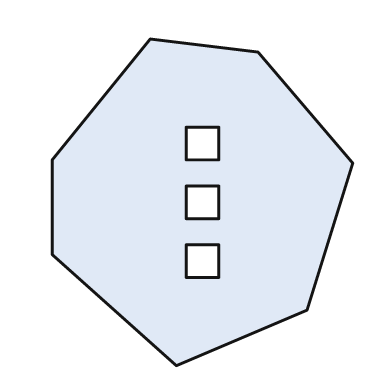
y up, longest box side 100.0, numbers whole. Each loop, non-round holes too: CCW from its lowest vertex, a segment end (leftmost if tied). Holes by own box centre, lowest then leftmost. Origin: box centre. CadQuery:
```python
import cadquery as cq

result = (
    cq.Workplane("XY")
    .moveTo(-8.0, -50.0)
    .lineTo(32.0, -33.0)
    .lineTo(46.0, 12.0)
    .lineTo(17.0, 46.0)
    .lineTo(-16.0, 50.0)
    .lineTo(-46.0, 13.0)
    .lineTo(-46.0, -16.0)
    .close()
    .moveTo(-5.0, -23.0)
    .lineTo(5.0, -23.0)
    .lineTo(5.0, -13.0)
    .lineTo(-5.0, -13.0)
    .close()
    .moveTo(-5.0, -5.0)
    .lineTo(5.0, -5.0)
    .lineTo(5.0, 5.0)
    .lineTo(-5.0, 5.0)
    .close()
    .moveTo(-5.0, 13.0)
    .lineTo(5.0, 13.0)
    .lineTo(5.0, 23.0)
    .lineTo(-5.0, 23.0)
    .close()
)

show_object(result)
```